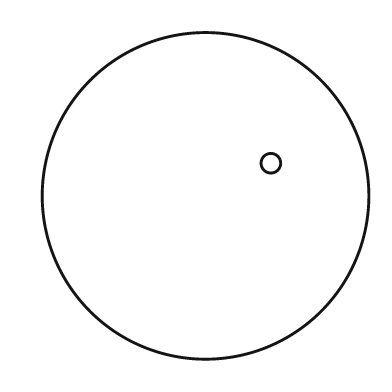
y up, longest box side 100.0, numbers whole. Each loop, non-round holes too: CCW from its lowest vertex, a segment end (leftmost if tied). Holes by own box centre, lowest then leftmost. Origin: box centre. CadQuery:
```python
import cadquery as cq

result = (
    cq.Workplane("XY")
    .moveTo(0.0, 0.0)
    .circle(50.0)
    .moveTo(20.0, 10.0)
    .circle(3.0)
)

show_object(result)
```